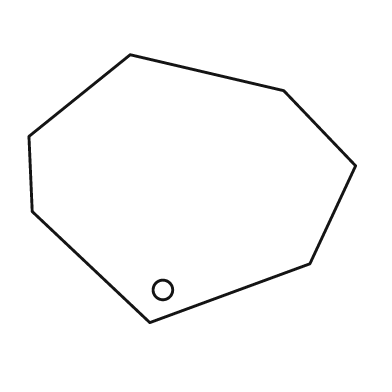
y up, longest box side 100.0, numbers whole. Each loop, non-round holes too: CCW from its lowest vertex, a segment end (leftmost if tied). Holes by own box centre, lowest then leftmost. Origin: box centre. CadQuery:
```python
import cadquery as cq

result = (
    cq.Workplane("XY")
    .moveTo(-13.0, -41.0)
    .lineTo(36.0, -23.0)
    .lineTo(50.0, 7.0)
    .lineTo(28.0, 30.0)
    .lineTo(-19.0, 41.0)
    .lineTo(-50.0, 16.0)
    .lineTo(-49.0, -7.0)
    .close()
    .moveTo(-9.0, -31.0)
    .circle(3.0)
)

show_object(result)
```